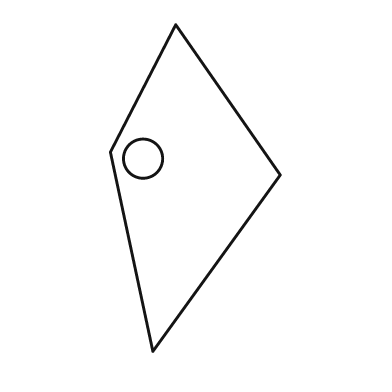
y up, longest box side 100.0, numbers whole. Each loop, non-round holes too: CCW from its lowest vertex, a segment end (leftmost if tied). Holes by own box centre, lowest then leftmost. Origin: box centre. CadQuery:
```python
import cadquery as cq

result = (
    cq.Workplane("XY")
    .moveTo(-13.0, -50.0)
    .lineTo(26.0, 4.0)
    .lineTo(-6.0, 50.0)
    .lineTo(-26.0, 11.0)
    .close()
    .moveTo(-16.0, 9.0)
    .circle(6.0)
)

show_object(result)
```